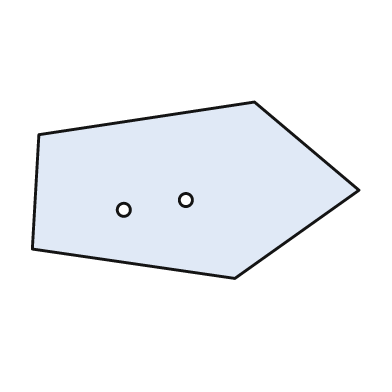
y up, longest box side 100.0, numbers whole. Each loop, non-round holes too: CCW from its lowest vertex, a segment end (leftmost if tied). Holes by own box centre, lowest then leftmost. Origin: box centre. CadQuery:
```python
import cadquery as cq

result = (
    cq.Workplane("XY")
    .moveTo(12.0, -27.0)
    .lineTo(50.0, 0.0)
    .lineTo(18.0, 27.0)
    .lineTo(-48.0, 17.0)
    .lineTo(-50.0, -18.0)
    .close()
    .moveTo(-22.0, -6.0)
    .circle(2.0)
    .moveTo(-3.0, -3.0)
    .circle(2.0)
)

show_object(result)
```